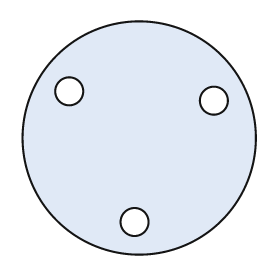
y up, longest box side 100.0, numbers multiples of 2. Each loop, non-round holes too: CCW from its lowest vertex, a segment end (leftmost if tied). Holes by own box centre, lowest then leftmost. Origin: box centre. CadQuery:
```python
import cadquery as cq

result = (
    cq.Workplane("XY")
    .moveTo(0.0, 0.0)
    .circle(50.0)
    .moveTo(-2.0, -36.0)
    .circle(6.0)
    .moveTo(32.0, 16.0)
    .circle(6.0)
    .moveTo(-30.0, 20.0)
    .circle(6.0)
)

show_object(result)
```